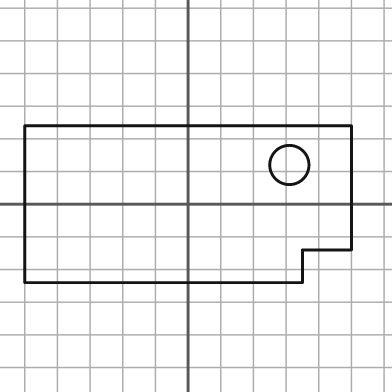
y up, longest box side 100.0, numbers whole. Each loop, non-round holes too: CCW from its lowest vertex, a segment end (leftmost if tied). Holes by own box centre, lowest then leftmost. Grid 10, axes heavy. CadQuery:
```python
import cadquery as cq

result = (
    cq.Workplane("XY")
    .moveTo(-50.0, -24.0)
    .lineTo(35.0, -24.0)
    .lineTo(35.0, -14.0)
    .lineTo(50.0, -14.0)
    .lineTo(50.0, 24.0)
    .lineTo(-50.0, 24.0)
    .close()
    .moveTo(31.0, 12.0)
    .circle(6.0)
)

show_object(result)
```